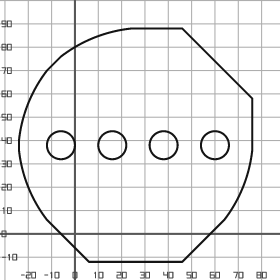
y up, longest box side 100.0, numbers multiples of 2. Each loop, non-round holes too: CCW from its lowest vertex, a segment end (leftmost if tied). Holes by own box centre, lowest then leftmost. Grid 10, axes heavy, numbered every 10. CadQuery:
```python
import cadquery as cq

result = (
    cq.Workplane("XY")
    .moveTo(6.0, -12.0)
    .lineTo(46.0, -12.0)
    .lineTo(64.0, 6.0)
    .threePointArc((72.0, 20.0), (76.0, 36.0))
    .lineTo(76.0, 58.0)
    .lineTo(46.0, 88.0)
    .lineTo(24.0, 88.0)
    .threePointArc((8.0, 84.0), (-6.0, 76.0))
    .lineTo(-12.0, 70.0)
    .threePointArc((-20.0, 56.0), (-24.0, 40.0))
    .lineTo(-24.0, 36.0)
    .threePointArc((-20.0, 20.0), (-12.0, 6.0))
    .close()
    .moveTo(-6.0, 38.0)
    .circle(6.0)
    .moveTo(16.0, 38.0)
    .circle(6.0)
    .moveTo(38.0, 38.0)
    .circle(6.0)
    .moveTo(60.0, 38.0)
    .circle(6.0)
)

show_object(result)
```